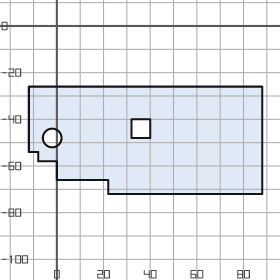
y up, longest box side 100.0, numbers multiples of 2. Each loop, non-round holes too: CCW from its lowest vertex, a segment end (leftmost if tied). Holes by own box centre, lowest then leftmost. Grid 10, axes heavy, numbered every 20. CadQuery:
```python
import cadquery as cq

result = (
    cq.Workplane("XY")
    .moveTo(22.0, -72.0)
    .lineTo(88.0, -72.0)
    .lineTo(88.0, -26.0)
    .lineTo(-12.0, -26.0)
    .lineTo(-12.0, -54.0)
    .lineTo(-8.0, -54.0)
    .lineTo(-8.0, -58.0)
    .lineTo(0.0, -58.0)
    .lineTo(0.0, -66.0)
    .lineTo(22.0, -66.0)
    .close()
    .moveTo(-2.0, -48.0)
    .circle(4.0)
    .moveTo(32.0, -48.0)
    .lineTo(40.0, -48.0)
    .lineTo(40.0, -40.0)
    .lineTo(32.0, -40.0)
    .close()
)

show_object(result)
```